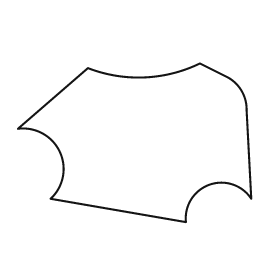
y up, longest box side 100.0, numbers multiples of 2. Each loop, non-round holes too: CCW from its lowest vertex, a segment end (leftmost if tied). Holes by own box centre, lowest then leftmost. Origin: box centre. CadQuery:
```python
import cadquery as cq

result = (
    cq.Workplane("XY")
    .moveTo(22.0, -34.0)
    .threePointArc((32.0, -18.0), (50.0, -24.0))
    .lineTo(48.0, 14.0)
    .threePointArc((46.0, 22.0), (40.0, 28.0))
    .lineTo(28.0, 34.0)
    .threePointArc((4.0, 28.0), (-20.0, 32.0))
    .lineTo(-50.0, 6.0)
    .threePointArc((-32.0, -4.0), (-36.0, -24.0))
    .close()
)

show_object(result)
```